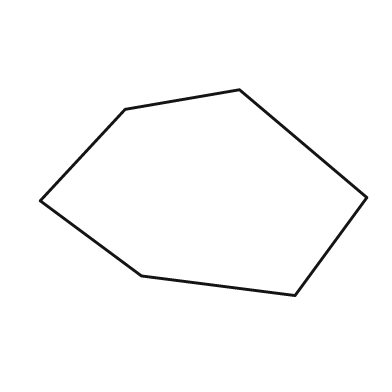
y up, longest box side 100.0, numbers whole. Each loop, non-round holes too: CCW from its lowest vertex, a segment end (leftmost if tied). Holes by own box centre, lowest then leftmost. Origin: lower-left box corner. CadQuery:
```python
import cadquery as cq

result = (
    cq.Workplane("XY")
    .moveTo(78.0, 0.0)
    .lineTo(100.0, 30.0)
    .lineTo(61.0, 63.0)
    .lineTo(26.0, 57.0)
    .lineTo(0.0, 29.0)
    .lineTo(31.0, 6.0)
    .close()
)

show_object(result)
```